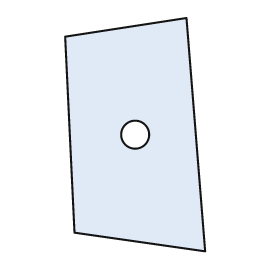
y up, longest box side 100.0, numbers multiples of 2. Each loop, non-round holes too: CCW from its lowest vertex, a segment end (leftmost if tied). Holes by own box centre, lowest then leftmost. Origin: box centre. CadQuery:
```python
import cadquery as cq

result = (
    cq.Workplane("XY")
    .moveTo(30.0, -50.0)
    .lineTo(22.0, 50.0)
    .lineTo(-30.0, 42.0)
    .lineTo(-26.0, -42.0)
    .close()
    .moveTo(0.0, 0.0)
    .circle(6.0)
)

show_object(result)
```